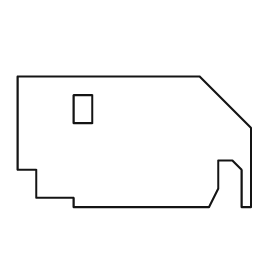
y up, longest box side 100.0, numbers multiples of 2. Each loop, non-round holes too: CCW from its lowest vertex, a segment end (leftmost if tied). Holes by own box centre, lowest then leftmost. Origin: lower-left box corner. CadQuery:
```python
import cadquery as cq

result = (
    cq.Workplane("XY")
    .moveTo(24.0, 0.0)
    .lineTo(82.0, 0.0)
    .lineTo(86.0, 8.0)
    .lineTo(86.0, 20.0)
    .lineTo(92.0, 20.0)
    .lineTo(96.0, 16.0)
    .lineTo(96.0, 0.0)
    .lineTo(100.0, 0.0)
    .lineTo(100.0, 34.0)
    .lineTo(78.0, 56.0)
    .lineTo(0.0, 56.0)
    .lineTo(0.0, 16.0)
    .lineTo(8.0, 16.0)
    .lineTo(8.0, 4.0)
    .lineTo(24.0, 4.0)
    .close()
    .moveTo(24.0, 36.0)
    .lineTo(32.0, 36.0)
    .lineTo(32.0, 48.0)
    .lineTo(24.0, 48.0)
    .close()
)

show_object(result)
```